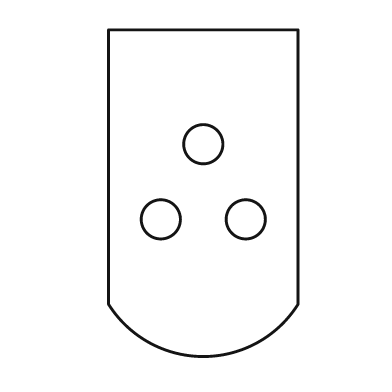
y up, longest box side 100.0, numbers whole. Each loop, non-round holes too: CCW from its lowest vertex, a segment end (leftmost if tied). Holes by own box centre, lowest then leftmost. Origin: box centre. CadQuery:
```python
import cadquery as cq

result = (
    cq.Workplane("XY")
    .moveTo(-29.0, -34.0)
    .threePointArc((0.0, -50.0), (29.0, -34.0))
    .lineTo(29.0, 50.0)
    .lineTo(-29.0, 50.0)
    .close()
    .moveTo(-13.0, -8.0)
    .circle(6.0)
    .moveTo(13.0, -8.0)
    .circle(6.0)
    .moveTo(0.0, 15.0)
    .circle(6.0)
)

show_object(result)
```